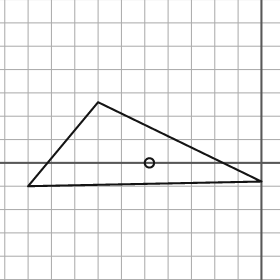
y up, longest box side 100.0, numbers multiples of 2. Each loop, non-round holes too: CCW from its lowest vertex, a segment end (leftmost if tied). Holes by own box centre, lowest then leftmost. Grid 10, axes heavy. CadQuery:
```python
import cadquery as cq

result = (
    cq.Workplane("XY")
    .moveTo(-100.0, -10.0)
    .lineTo(0.0, -8.0)
    .lineTo(-70.0, 26.0)
    .close()
    .moveTo(-48.0, 0.0)
    .circle(2.0)
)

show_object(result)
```